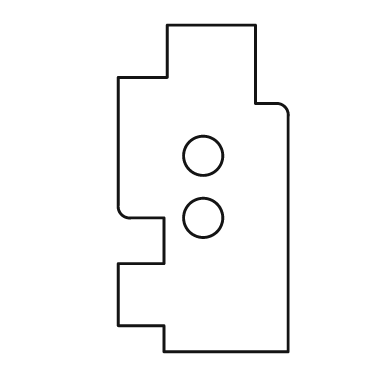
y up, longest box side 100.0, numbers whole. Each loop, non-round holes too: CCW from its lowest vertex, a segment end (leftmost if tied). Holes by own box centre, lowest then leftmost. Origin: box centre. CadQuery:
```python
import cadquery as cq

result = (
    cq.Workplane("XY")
    .moveTo(-12.0, -50.0)
    .lineTo(26.0, -50.0)
    .lineTo(26.0, 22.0)
    .threePointArc((25.0, 25.0), (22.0, 26.0))
    .lineTo(16.0, 26.0)
    .lineTo(16.0, 50.0)
    .lineTo(-11.0, 50.0)
    .lineTo(-11.0, 34.0)
    .lineTo(-26.0, 34.0)
    .lineTo(-26.0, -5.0)
    .threePointArc((-25.0, -8.0), (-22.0, -9.0))
    .lineTo(-12.0, -9.0)
    .lineTo(-12.0, -23.0)
    .lineTo(-26.0, -23.0)
    .lineTo(-26.0, -42.0)
    .lineTo(-12.0, -42.0)
    .close()
    .moveTo(0.0, -9.0)
    .circle(6.0)
    .moveTo(0.0, 10.0)
    .circle(6.0)
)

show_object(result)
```